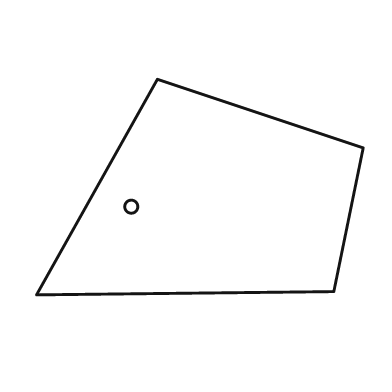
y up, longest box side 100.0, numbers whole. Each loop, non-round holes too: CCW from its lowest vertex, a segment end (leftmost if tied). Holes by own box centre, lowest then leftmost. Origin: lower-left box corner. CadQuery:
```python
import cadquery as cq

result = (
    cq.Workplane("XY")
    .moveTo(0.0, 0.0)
    .lineTo(91.0, 1.0)
    .lineTo(100.0, 45.0)
    .lineTo(37.0, 66.0)
    .close()
    .moveTo(29.0, 27.0)
    .circle(2.0)
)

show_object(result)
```